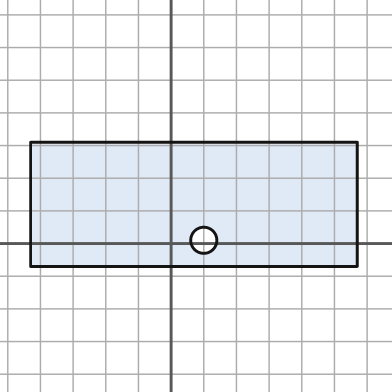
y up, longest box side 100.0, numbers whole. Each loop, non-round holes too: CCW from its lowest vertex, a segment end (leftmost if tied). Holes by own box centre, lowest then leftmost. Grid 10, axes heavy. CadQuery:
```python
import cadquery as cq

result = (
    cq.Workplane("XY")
    .moveTo(-43.0, -7.0)
    .lineTo(57.0, -7.0)
    .lineTo(57.0, 31.0)
    .lineTo(-43.0, 31.0)
    .close()
    .moveTo(10.0, 1.0)
    .circle(4.0)
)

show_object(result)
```